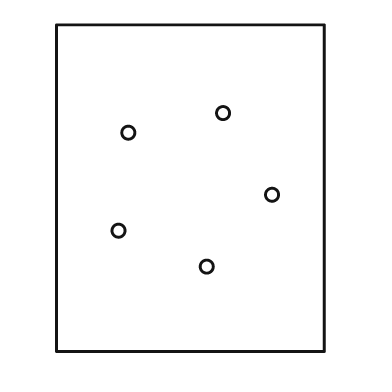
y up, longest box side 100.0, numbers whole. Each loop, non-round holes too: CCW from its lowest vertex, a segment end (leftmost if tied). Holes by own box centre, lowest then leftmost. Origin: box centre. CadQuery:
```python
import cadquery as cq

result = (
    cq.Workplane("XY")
    .moveTo(-41.0, -50.0)
    .lineTo(41.0, -50.0)
    .lineTo(41.0, 50.0)
    .lineTo(-41.0, 50.0)
    .close()
    .moveTo(5.0, -24.0)
    .circle(2.0)
    .moveTo(-22.0, -13.0)
    .circle(2.0)
    .moveTo(25.0, -2.0)
    .circle(2.0)
    .moveTo(-19.0, 17.0)
    .circle(2.0)
    .moveTo(10.0, 23.0)
    .circle(2.0)
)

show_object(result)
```